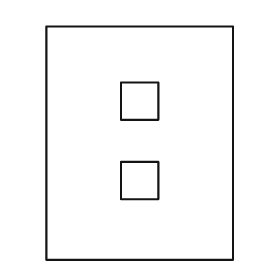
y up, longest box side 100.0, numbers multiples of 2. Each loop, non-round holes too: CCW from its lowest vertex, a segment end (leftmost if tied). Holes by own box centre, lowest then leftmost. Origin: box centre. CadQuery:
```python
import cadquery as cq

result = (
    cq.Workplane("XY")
    .moveTo(-40.0, -50.0)
    .lineTo(40.0, -50.0)
    .lineTo(40.0, 50.0)
    .lineTo(-40.0, 50.0)
    .close()
    .moveTo(-8.0, -24.0)
    .lineTo(8.0, -24.0)
    .lineTo(8.0, -8.0)
    .lineTo(-8.0, -8.0)
    .close()
    .moveTo(-8.0, 10.0)
    .lineTo(8.0, 10.0)
    .lineTo(8.0, 26.0)
    .lineTo(-8.0, 26.0)
    .close()
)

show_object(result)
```